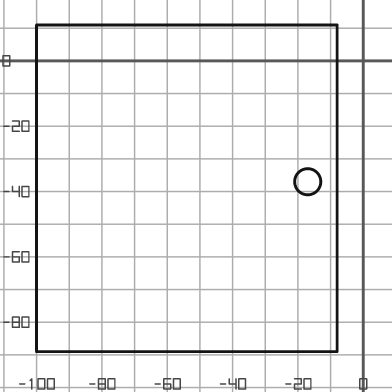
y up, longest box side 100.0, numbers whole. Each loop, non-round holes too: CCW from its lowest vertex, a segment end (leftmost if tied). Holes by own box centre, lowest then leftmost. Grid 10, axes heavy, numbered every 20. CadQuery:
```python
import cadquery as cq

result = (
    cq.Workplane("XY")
    .moveTo(-100.0, -89.0)
    .lineTo(-8.0, -89.0)
    .lineTo(-8.0, 11.0)
    .lineTo(-100.0, 11.0)
    .close()
    .moveTo(-17.0, -37.0)
    .circle(4.0)
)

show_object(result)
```